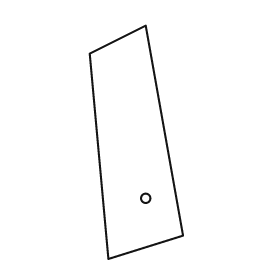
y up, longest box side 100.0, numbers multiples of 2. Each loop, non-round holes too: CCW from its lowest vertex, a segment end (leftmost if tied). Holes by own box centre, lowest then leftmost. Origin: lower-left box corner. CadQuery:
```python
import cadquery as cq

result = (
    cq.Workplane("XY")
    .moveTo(8.0, 0.0)
    .lineTo(40.0, 10.0)
    .lineTo(24.0, 100.0)
    .lineTo(0.0, 88.0)
    .close()
    .moveTo(24.0, 26.0)
    .circle(2.0)
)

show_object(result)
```